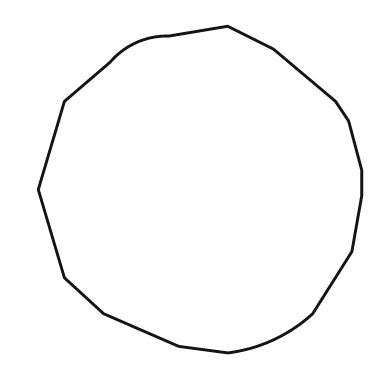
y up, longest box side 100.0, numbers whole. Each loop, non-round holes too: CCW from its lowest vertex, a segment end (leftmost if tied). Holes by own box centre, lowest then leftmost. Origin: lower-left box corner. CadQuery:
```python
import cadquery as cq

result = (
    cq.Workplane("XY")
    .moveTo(58.0, 0.0)
    .threePointArc((72.0, 4.0), (84.0, 12.0))
    .lineTo(96.0, 31.0)
    .lineTo(99.0, 48.0)
    .lineTo(99.0, 56.0)
    .lineTo(95.0, 71.0)
    .lineTo(91.0, 77.0)
    .lineTo(72.0, 93.0)
    .lineTo(58.0, 100.0)
    .lineTo(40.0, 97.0)
    .threePointArc((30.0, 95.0), (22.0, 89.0))
    .lineTo(8.0, 77.0)
    .lineTo(0.0, 50.0)
    .lineTo(8.0, 23.0)
    .lineTo(20.0, 12.0)
    .lineTo(43.0, 2.0)
    .close()
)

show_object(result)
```